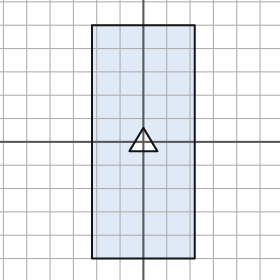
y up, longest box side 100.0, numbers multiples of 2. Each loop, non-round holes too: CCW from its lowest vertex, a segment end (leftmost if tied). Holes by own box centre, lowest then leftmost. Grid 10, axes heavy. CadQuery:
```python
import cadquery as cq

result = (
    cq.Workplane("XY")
    .moveTo(-22.0, -50.0)
    .lineTo(22.0, -50.0)
    .lineTo(22.0, 50.0)
    .lineTo(-22.0, 50.0)
    .close()
    .moveTo(-6.0, -4.0)
    .lineTo(6.0, -4.0)
    .lineTo(0.0, 6.0)
    .close()
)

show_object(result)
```